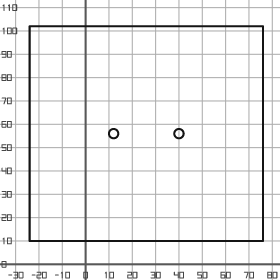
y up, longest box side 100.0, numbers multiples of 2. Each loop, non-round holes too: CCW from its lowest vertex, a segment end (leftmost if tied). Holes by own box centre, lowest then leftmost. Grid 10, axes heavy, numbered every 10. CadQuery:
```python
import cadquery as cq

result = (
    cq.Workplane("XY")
    .moveTo(-24.0, 10.0)
    .lineTo(76.0, 10.0)
    .lineTo(76.0, 102.0)
    .lineTo(-24.0, 102.0)
    .close()
    .moveTo(12.0, 56.0)
    .circle(2.0)
    .moveTo(40.0, 56.0)
    .circle(2.0)
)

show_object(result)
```